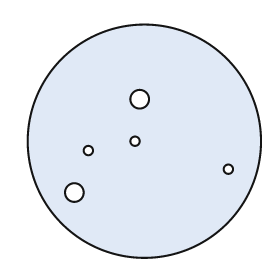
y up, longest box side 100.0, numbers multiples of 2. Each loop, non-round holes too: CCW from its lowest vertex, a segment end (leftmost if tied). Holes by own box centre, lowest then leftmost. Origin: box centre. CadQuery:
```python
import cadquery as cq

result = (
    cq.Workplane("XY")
    .moveTo(0.0, 0.0)
    .circle(50.0)
    .moveTo(-30.0, -22.0)
    .circle(4.0)
    .moveTo(36.0, -12.0)
    .circle(2.0)
    .moveTo(-24.0, -4.0)
    .circle(2.0)
    .moveTo(-4.0, 0.0)
    .circle(2.0)
    .moveTo(-2.0, 18.0)
    .circle(4.0)
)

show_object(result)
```